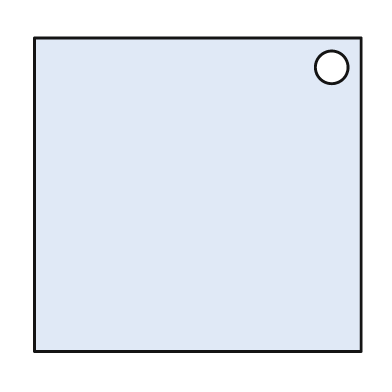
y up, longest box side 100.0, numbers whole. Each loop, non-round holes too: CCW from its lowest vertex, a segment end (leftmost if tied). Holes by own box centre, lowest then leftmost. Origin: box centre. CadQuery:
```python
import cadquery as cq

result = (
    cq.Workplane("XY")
    .moveTo(-50.0, -48.0)
    .lineTo(50.0, -48.0)
    .lineTo(50.0, 48.0)
    .lineTo(-50.0, 48.0)
    .close()
    .moveTo(41.0, 39.0)
    .circle(5.0)
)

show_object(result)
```